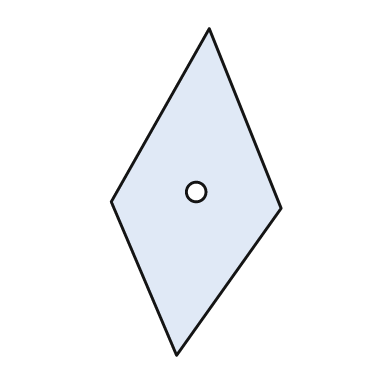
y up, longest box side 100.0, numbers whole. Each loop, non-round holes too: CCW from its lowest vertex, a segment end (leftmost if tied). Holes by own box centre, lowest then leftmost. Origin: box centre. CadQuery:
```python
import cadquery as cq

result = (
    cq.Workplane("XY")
    .moveTo(-6.0, -50.0)
    .lineTo(26.0, -5.0)
    .lineTo(4.0, 50.0)
    .lineTo(-26.0, -3.0)
    .close()
    .moveTo(0.0, 0.0)
    .circle(3.0)
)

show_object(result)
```